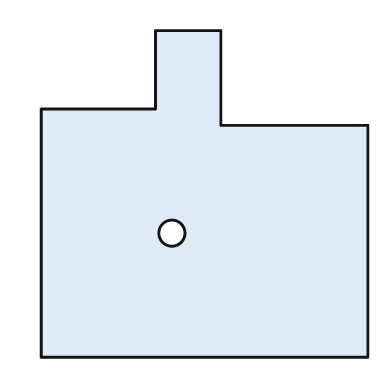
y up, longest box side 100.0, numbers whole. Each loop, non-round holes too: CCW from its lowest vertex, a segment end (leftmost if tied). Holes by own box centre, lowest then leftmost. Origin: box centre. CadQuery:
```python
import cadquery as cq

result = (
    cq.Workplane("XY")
    .moveTo(-50.0, -50.0)
    .lineTo(50.0, -50.0)
    .lineTo(50.0, 21.0)
    .lineTo(5.0, 21.0)
    .lineTo(5.0, 50.0)
    .lineTo(-15.0, 50.0)
    .lineTo(-15.0, 26.0)
    .lineTo(-50.0, 26.0)
    .close()
    .moveTo(-10.0, -12.0)
    .circle(4.0)
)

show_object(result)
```